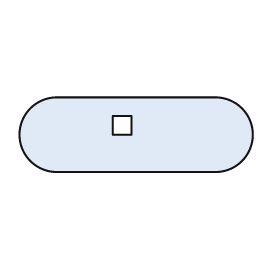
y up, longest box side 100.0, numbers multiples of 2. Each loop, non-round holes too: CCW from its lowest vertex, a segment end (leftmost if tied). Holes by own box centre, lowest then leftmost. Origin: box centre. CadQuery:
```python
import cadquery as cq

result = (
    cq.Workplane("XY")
    .moveTo(-34.0, -16.0)
    .lineTo(34.0, -16.0)
    .threePointArc((50.0, 0.0), (34.0, 16.0))
    .lineTo(-34.0, 16.0)
    .threePointArc((-50.0, 0.0), (-34.0, -16.0))
    .close()
    .moveTo(-10.0, 0.0)
    .lineTo(-2.0, 0.0)
    .lineTo(-2.0, 8.0)
    .lineTo(-10.0, 8.0)
    .close()
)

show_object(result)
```